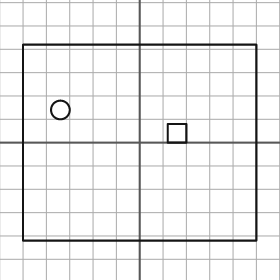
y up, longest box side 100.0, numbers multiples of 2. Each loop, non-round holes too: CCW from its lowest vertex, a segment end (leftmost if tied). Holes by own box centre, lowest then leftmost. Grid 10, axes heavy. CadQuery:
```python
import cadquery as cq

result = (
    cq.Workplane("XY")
    .moveTo(-50.0, -42.0)
    .lineTo(50.0, -42.0)
    .lineTo(50.0, 42.0)
    .lineTo(-50.0, 42.0)
    .close()
    .moveTo(12.0, 0.0)
    .lineTo(20.0, 0.0)
    .lineTo(20.0, 8.0)
    .lineTo(12.0, 8.0)
    .close()
    .moveTo(-34.0, 14.0)
    .circle(4.0)
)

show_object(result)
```